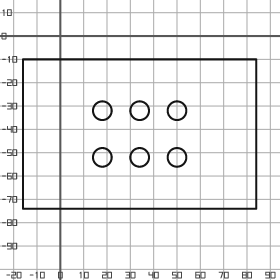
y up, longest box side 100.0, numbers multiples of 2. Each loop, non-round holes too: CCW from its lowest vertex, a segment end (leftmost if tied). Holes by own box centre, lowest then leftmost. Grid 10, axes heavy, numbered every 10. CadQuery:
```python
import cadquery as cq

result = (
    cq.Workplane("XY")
    .moveTo(-16.0, -74.0)
    .lineTo(84.0, -74.0)
    .lineTo(84.0, -10.0)
    .lineTo(-16.0, -10.0)
    .close()
    .moveTo(18.0, -52.0)
    .circle(4.0)
    .moveTo(34.0, -52.0)
    .circle(4.0)
    .moveTo(50.0, -52.0)
    .circle(4.0)
    .moveTo(18.0, -32.0)
    .circle(4.0)
    .moveTo(34.0, -32.0)
    .circle(4.0)
    .moveTo(50.0, -32.0)
    .circle(4.0)
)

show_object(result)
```